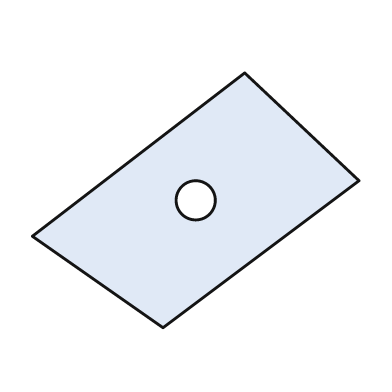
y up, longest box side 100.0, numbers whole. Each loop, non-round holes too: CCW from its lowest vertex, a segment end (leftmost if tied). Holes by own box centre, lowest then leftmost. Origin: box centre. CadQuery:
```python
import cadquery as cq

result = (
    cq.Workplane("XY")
    .moveTo(-10.0, -39.0)
    .lineTo(50.0, 6.0)
    .lineTo(15.0, 39.0)
    .lineTo(-50.0, -11.0)
    .close()
    .moveTo(0.0, 0.0)
    .circle(6.0)
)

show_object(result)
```